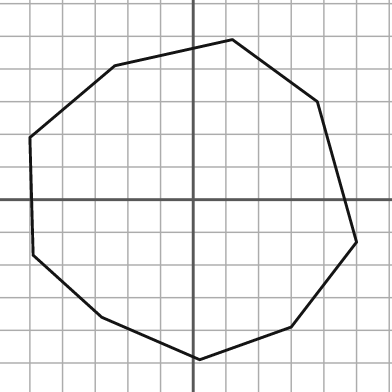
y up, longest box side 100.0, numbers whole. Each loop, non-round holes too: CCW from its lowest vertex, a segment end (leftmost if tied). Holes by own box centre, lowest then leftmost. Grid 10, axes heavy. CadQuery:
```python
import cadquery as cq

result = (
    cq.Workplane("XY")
    .moveTo(2.0, -49.0)
    .lineTo(30.0, -39.0)
    .lineTo(50.0, -13.0)
    .lineTo(38.0, 30.0)
    .lineTo(12.0, 49.0)
    .lineTo(-24.0, 41.0)
    .lineTo(-50.0, 19.0)
    .lineTo(-49.0, -17.0)
    .lineTo(-28.0, -36.0)
    .close()
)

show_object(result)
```